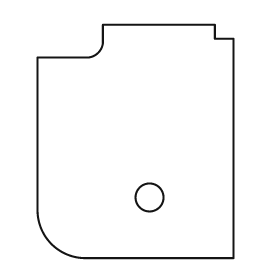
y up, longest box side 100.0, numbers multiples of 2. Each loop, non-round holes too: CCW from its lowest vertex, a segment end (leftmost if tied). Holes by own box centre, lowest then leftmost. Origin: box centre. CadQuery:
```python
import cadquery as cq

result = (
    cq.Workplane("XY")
    .moveTo(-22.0, -50.0)
    .lineTo(42.0, -50.0)
    .lineTo(42.0, 44.0)
    .lineTo(34.0, 44.0)
    .lineTo(34.0, 50.0)
    .lineTo(-14.0, 50.0)
    .lineTo(-14.0, 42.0)
    .threePointArc((-16.0, 38.0), (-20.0, 36.0))
    .lineTo(-42.0, 36.0)
    .lineTo(-42.0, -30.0)
    .threePointArc((-36.0, -44.0), (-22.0, -50.0))
    .close()
    .moveTo(6.0, -24.0)
    .circle(6.0)
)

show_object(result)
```